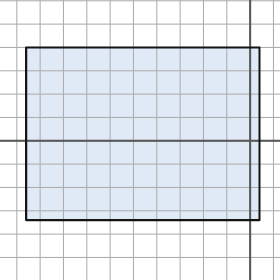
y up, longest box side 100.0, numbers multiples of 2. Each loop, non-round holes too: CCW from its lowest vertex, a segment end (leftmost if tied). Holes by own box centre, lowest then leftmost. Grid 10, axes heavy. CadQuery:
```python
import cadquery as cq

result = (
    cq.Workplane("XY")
    .moveTo(-96.0, -34.0)
    .lineTo(4.0, -34.0)
    .lineTo(4.0, 40.0)
    .lineTo(-96.0, 40.0)
    .close()
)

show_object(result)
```